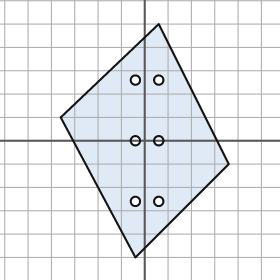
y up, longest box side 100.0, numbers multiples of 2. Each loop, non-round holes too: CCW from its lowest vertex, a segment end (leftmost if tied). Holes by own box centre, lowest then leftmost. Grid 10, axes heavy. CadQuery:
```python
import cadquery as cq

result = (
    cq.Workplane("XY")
    .moveTo(-4.0, -50.0)
    .lineTo(36.0, -10.0)
    .lineTo(6.0, 50.0)
    .lineTo(-36.0, 10.0)
    .close()
    .moveTo(-4.0, -26.0)
    .circle(2.0)
    .moveTo(6.0, -26.0)
    .circle(2.0)
    .moveTo(-4.0, 0.0)
    .circle(2.0)
    .moveTo(6.0, 0.0)
    .circle(2.0)
    .moveTo(-4.0, 26.0)
    .circle(2.0)
    .moveTo(6.0, 26.0)
    .circle(2.0)
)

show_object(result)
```